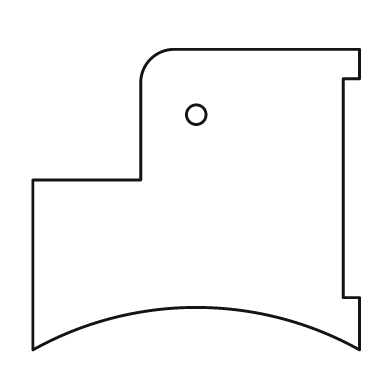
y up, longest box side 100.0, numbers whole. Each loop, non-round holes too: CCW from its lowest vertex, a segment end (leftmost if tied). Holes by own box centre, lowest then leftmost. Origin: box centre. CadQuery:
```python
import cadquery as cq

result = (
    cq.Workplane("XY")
    .moveTo(-50.0, -46.0)
    .threePointArc((0.0, -33.0), (50.0, -46.0))
    .lineTo(50.0, -30.0)
    .lineTo(45.0, -30.0)
    .lineTo(45.0, 37.0)
    .lineTo(50.0, 37.0)
    .lineTo(50.0, 46.0)
    .lineTo(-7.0, 46.0)
    .threePointArc((-14.0, 43.0), (-17.0, 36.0))
    .lineTo(-17.0, 6.0)
    .lineTo(-50.0, 6.0)
    .close()
    .moveTo(0.0, 26.0)
    .circle(3.0)
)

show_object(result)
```